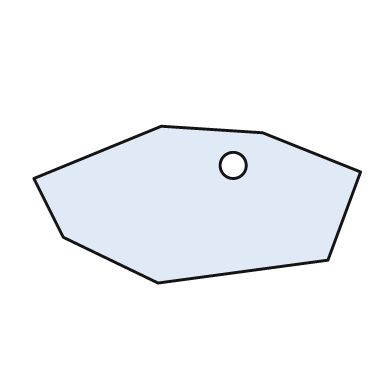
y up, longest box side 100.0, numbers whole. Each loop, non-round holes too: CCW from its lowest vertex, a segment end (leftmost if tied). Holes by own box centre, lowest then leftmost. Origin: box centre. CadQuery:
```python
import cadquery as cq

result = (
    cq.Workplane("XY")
    .moveTo(-12.0, -24.0)
    .lineTo(40.0, -17.0)
    .lineTo(50.0, 10.0)
    .lineTo(20.0, 22.0)
    .lineTo(-11.0, 24.0)
    .lineTo(-50.0, 8.0)
    .lineTo(-41.0, -10.0)
    .close()
    .moveTo(11.0, 12.0)
    .circle(4.0)
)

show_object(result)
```